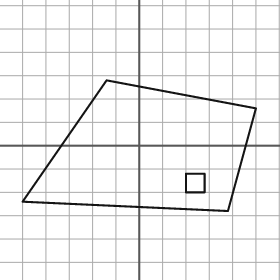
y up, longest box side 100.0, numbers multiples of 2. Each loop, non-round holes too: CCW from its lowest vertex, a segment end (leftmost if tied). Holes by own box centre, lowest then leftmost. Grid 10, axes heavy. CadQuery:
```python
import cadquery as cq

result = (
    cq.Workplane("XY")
    .moveTo(38.0, -28.0)
    .lineTo(50.0, 16.0)
    .lineTo(-14.0, 28.0)
    .lineTo(-50.0, -24.0)
    .close()
    .moveTo(20.0, -20.0)
    .lineTo(28.0, -20.0)
    .lineTo(28.0, -12.0)
    .lineTo(20.0, -12.0)
    .close()
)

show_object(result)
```